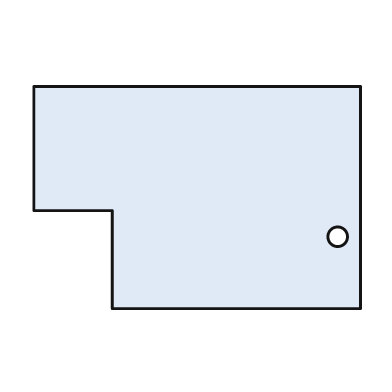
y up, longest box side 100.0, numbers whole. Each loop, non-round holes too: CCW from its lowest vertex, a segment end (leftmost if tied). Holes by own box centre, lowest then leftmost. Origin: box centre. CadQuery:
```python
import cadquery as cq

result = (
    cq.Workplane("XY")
    .moveTo(-26.0, -34.0)
    .lineTo(50.0, -34.0)
    .lineTo(50.0, 34.0)
    .lineTo(-50.0, 34.0)
    .lineTo(-50.0, -4.0)
    .lineTo(-26.0, -4.0)
    .close()
    .moveTo(43.0, -12.0)
    .circle(3.0)
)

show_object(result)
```